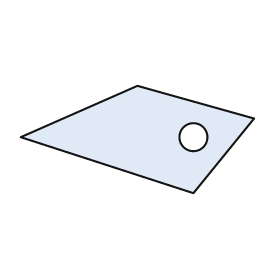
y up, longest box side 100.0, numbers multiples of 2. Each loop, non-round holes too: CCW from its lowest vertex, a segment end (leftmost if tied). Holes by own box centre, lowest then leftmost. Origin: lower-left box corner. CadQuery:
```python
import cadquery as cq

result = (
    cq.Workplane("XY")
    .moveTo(74.0, 0.0)
    .lineTo(100.0, 32.0)
    .lineTo(50.0, 46.0)
    .lineTo(0.0, 24.0)
    .close()
    .moveTo(74.0, 24.0)
    .circle(6.0)
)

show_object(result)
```